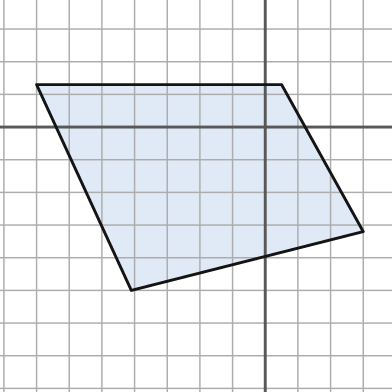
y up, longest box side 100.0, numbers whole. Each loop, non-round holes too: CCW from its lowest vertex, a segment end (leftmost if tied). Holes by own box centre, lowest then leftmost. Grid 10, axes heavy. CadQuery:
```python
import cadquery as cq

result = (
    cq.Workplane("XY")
    .moveTo(-41.0, -50.0)
    .lineTo(30.0, -32.0)
    .lineTo(5.0, 13.0)
    .lineTo(-70.0, 13.0)
    .close()
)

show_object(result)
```